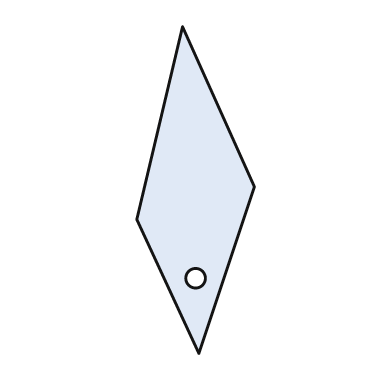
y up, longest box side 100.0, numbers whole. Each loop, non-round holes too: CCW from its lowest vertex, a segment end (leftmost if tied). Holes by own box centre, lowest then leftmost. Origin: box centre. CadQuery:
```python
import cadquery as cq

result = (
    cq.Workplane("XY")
    .moveTo(1.0, -50.0)
    .lineTo(18.0, 1.0)
    .lineTo(-4.0, 50.0)
    .lineTo(-18.0, -9.0)
    .close()
    .moveTo(0.0, -27.0)
    .circle(3.0)
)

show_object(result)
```